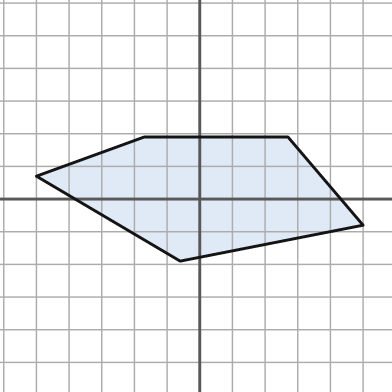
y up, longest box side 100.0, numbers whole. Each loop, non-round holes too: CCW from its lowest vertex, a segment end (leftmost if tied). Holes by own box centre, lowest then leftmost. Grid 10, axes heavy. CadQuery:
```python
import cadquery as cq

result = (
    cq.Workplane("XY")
    .moveTo(-6.0, -19.0)
    .lineTo(50.0, -8.0)
    .lineTo(27.0, 19.0)
    .lineTo(-17.0, 19.0)
    .lineTo(-50.0, 7.0)
    .close()
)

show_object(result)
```